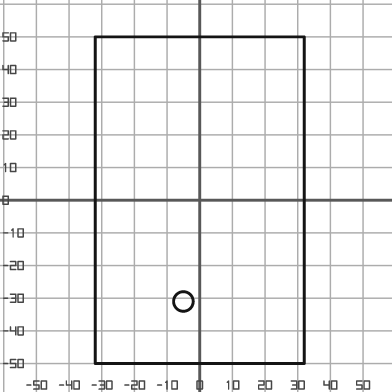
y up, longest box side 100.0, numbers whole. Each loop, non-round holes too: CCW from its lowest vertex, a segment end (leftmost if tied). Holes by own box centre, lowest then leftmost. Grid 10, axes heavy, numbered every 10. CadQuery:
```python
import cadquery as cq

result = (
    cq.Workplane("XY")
    .moveTo(-32.0, -50.0)
    .lineTo(32.0, -50.0)
    .lineTo(32.0, 50.0)
    .lineTo(-32.0, 50.0)
    .close()
    .moveTo(-5.0, -31.0)
    .circle(3.0)
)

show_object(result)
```